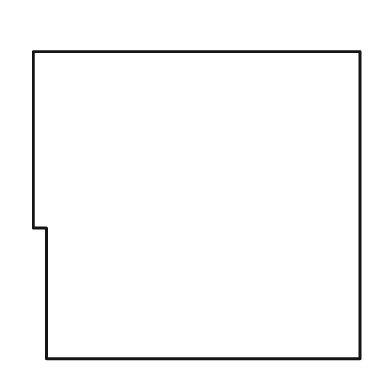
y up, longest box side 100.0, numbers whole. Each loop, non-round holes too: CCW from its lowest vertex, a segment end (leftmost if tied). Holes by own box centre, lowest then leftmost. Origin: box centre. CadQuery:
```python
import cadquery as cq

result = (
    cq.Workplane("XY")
    .moveTo(-46.0, -47.0)
    .lineTo(50.0, -47.0)
    .lineTo(50.0, 47.0)
    .lineTo(-50.0, 47.0)
    .lineTo(-50.0, -7.0)
    .lineTo(-46.0, -7.0)
    .close()
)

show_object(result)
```